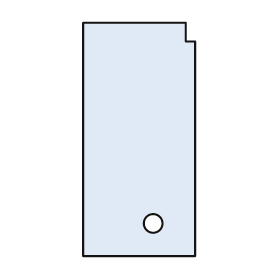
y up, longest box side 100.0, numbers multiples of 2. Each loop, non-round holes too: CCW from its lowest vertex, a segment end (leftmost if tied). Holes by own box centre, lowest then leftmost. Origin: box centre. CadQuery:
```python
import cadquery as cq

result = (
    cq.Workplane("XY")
    .moveTo(-24.0, -50.0)
    .lineTo(24.0, -50.0)
    .lineTo(24.0, 42.0)
    .lineTo(20.0, 42.0)
    .lineTo(20.0, 50.0)
    .lineTo(-24.0, 50.0)
    .close()
    .moveTo(6.0, -36.0)
    .circle(4.0)
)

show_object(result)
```